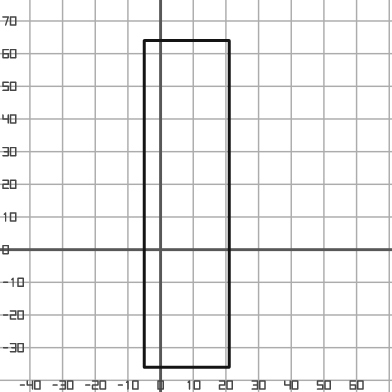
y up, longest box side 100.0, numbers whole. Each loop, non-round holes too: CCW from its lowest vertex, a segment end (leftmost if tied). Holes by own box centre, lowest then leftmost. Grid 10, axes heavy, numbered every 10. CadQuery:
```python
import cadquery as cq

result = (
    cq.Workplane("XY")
    .moveTo(-5.0, -36.0)
    .lineTo(21.0, -36.0)
    .lineTo(21.0, 64.0)
    .lineTo(-5.0, 64.0)
    .close()
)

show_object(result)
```